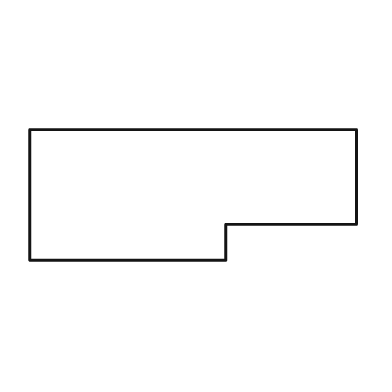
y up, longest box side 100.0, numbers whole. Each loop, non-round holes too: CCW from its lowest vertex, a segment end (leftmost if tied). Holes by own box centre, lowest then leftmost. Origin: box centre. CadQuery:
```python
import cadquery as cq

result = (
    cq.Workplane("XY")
    .moveTo(-50.0, -20.0)
    .lineTo(10.0, -20.0)
    .lineTo(10.0, -9.0)
    .lineTo(50.0, -9.0)
    .lineTo(50.0, 20.0)
    .lineTo(-50.0, 20.0)
    .close()
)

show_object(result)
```